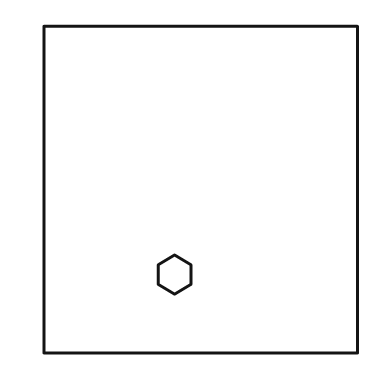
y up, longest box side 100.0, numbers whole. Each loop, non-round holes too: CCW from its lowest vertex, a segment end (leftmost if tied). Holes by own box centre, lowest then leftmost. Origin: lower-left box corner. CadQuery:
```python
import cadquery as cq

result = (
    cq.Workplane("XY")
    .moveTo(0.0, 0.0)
    .lineTo(96.0, 0.0)
    .lineTo(96.0, 100.0)
    .lineTo(0.0, 100.0)
    .close()
    .moveTo(40.0, 18.0)
    .lineTo(45.0, 21.0)
    .lineTo(45.0, 27.0)
    .lineTo(40.0, 30.0)
    .lineTo(35.0, 27.0)
    .lineTo(35.0, 21.0)
    .close()
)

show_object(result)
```